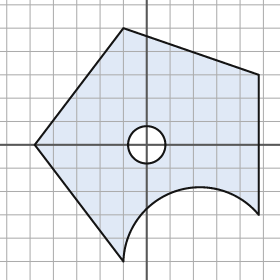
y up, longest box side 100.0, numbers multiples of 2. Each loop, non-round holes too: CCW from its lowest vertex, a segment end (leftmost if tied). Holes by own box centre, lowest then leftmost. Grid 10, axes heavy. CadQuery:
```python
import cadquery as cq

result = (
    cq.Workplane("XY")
    .moveTo(-10.0, -50.0)
    .threePointArc((12.0, -20.0), (48.0, -30.0))
    .lineTo(48.0, 30.0)
    .lineTo(-10.0, 50.0)
    .lineTo(-48.0, 0.0)
    .close()
    .moveTo(0.0, 0.0)
    .circle(8.0)
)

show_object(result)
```